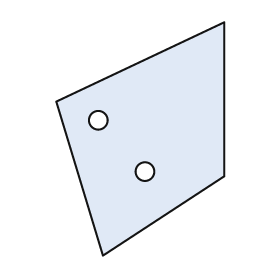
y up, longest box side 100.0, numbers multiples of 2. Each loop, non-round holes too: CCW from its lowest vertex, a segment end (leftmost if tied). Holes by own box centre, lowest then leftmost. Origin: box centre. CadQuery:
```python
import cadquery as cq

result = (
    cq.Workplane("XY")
    .moveTo(-16.0, -50.0)
    .lineTo(36.0, -16.0)
    .lineTo(36.0, 50.0)
    .lineTo(-36.0, 16.0)
    .close()
    .moveTo(2.0, -14.0)
    .circle(4.0)
    .moveTo(-18.0, 8.0)
    .circle(4.0)
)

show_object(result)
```